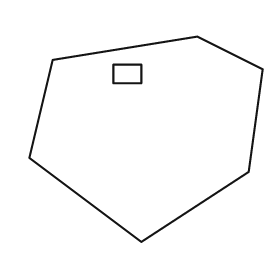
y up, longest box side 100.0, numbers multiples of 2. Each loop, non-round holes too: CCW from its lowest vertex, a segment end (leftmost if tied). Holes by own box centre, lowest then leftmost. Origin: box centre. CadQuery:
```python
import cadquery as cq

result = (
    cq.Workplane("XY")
    .moveTo(-2.0, -44.0)
    .lineTo(44.0, -14.0)
    .lineTo(50.0, 30.0)
    .lineTo(22.0, 44.0)
    .lineTo(-40.0, 34.0)
    .lineTo(-50.0, -8.0)
    .close()
    .moveTo(-14.0, 24.0)
    .lineTo(-2.0, 24.0)
    .lineTo(-2.0, 32.0)
    .lineTo(-14.0, 32.0)
    .close()
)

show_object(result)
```